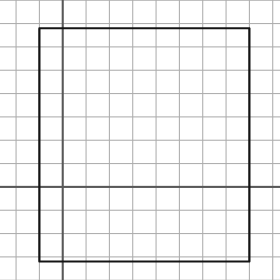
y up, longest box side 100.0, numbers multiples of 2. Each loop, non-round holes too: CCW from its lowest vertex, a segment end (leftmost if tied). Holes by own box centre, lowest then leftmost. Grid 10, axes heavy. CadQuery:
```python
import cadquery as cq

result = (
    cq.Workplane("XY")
    .moveTo(-10.0, -32.0)
    .lineTo(80.0, -32.0)
    .lineTo(80.0, 68.0)
    .lineTo(-10.0, 68.0)
    .close()
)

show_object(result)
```